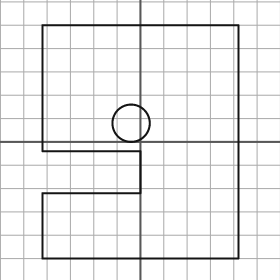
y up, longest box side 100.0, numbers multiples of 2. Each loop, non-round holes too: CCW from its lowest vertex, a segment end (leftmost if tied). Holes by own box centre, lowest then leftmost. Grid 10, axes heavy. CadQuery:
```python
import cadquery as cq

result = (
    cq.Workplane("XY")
    .moveTo(-42.0, -50.0)
    .lineTo(42.0, -50.0)
    .lineTo(42.0, 50.0)
    .lineTo(-42.0, 50.0)
    .lineTo(-42.0, -4.0)
    .lineTo(0.0, -4.0)
    .lineTo(0.0, -22.0)
    .lineTo(-42.0, -22.0)
    .close()
    .moveTo(-4.0, 8.0)
    .circle(8.0)
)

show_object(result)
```